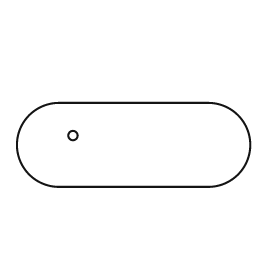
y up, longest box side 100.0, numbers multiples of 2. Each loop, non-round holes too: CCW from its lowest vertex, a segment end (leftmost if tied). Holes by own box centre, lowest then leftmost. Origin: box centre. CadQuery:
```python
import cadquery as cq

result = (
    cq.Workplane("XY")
    .moveTo(-32.0, -18.0)
    .lineTo(32.0, -18.0)
    .threePointArc((50.0, 0.0), (32.0, 18.0))
    .lineTo(-32.0, 18.0)
    .threePointArc((-50.0, 0.0), (-32.0, -18.0))
    .close()
    .moveTo(-26.0, 4.0)
    .circle(2.0)
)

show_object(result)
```